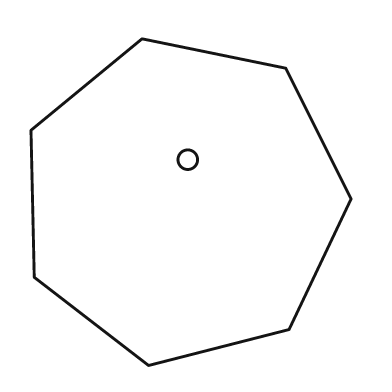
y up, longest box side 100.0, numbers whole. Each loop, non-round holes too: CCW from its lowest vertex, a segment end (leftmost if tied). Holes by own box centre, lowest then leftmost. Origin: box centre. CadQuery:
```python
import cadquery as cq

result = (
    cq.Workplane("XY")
    .moveTo(-13.0, -50.0)
    .lineTo(30.0, -39.0)
    .lineTo(49.0, 1.0)
    .lineTo(29.0, 41.0)
    .lineTo(-15.0, 50.0)
    .lineTo(-49.0, 22.0)
    .lineTo(-48.0, -23.0)
    .close()
    .moveTo(-1.0, 13.0)
    .circle(3.0)
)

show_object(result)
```